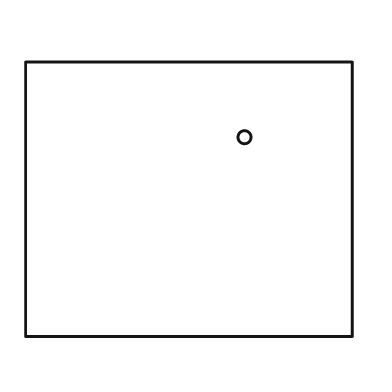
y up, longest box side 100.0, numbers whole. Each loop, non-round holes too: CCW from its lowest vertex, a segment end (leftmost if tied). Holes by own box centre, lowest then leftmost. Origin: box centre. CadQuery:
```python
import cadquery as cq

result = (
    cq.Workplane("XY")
    .moveTo(-50.0, -42.0)
    .lineTo(50.0, -42.0)
    .lineTo(50.0, 42.0)
    .lineTo(-50.0, 42.0)
    .close()
    .moveTo(17.0, 19.0)
    .circle(2.0)
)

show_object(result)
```